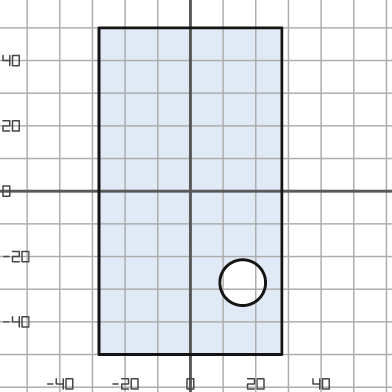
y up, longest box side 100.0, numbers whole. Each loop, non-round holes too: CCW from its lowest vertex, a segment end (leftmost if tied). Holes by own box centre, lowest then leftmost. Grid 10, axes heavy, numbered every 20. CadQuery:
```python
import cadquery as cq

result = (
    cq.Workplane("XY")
    .moveTo(-28.0, -50.0)
    .lineTo(28.0, -50.0)
    .lineTo(28.0, 50.0)
    .lineTo(-28.0, 50.0)
    .close()
    .moveTo(16.0, -28.0)
    .circle(7.0)
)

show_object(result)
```